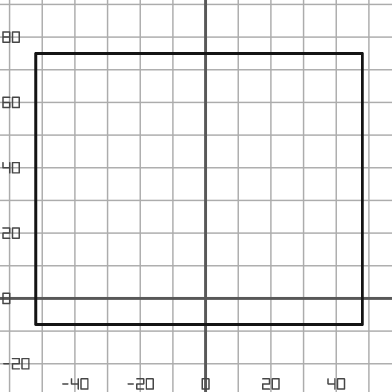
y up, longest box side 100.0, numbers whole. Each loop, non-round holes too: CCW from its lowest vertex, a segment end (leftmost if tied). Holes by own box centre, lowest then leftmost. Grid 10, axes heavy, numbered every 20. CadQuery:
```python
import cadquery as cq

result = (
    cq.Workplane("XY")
    .moveTo(-52.0, -8.0)
    .lineTo(48.0, -8.0)
    .lineTo(48.0, 75.0)
    .lineTo(-52.0, 75.0)
    .close()
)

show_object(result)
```